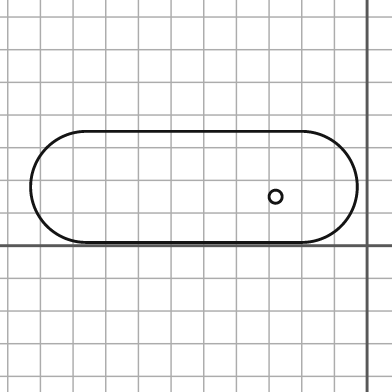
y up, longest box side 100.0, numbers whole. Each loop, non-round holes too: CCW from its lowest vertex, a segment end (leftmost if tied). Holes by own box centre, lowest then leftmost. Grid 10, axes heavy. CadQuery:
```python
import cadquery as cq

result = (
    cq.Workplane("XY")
    .moveTo(-86.0, 1.0)
    .lineTo(-20.0, 1.0)
    .threePointArc((-3.0, 18.0), (-20.0, 35.0))
    .lineTo(-86.0, 35.0)
    .threePointArc((-103.0, 18.0), (-86.0, 1.0))
    .close()
    .moveTo(-28.0, 15.0)
    .circle(2.0)
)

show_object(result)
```